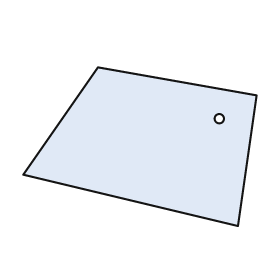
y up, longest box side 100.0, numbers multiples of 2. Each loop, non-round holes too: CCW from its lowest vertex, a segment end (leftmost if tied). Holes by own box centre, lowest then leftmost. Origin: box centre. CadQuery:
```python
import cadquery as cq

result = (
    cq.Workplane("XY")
    .moveTo(42.0, -34.0)
    .lineTo(50.0, 22.0)
    .lineTo(-18.0, 34.0)
    .lineTo(-50.0, -12.0)
    .close()
    .moveTo(34.0, 12.0)
    .circle(2.0)
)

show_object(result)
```